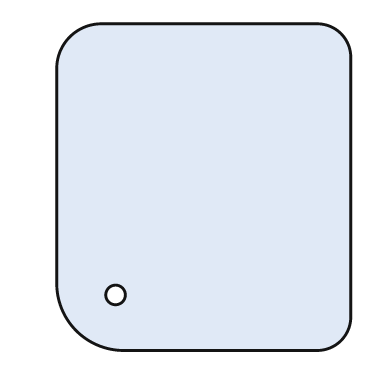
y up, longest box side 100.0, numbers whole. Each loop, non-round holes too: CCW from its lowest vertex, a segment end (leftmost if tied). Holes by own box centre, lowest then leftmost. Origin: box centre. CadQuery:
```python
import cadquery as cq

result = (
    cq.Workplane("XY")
    .moveTo(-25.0, -50.0)
    .lineTo(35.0, -50.0)
    .threePointArc((42.0, -47.0), (45.0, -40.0))
    .lineTo(45.0, 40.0)
    .threePointArc((42.0, 47.0), (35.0, 50.0))
    .lineTo(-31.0, 50.0)
    .threePointArc((-41.0, 46.0), (-45.0, 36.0))
    .lineTo(-45.0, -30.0)
    .threePointArc((-39.0, -44.0), (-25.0, -50.0))
    .close()
    .moveTo(-27.0, -33.0)
    .circle(3.0)
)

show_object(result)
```